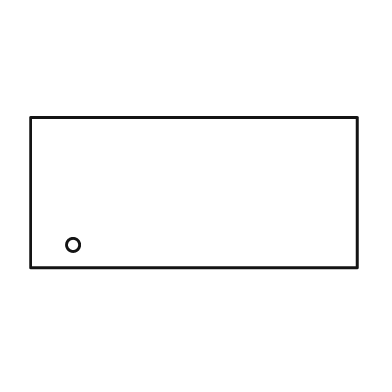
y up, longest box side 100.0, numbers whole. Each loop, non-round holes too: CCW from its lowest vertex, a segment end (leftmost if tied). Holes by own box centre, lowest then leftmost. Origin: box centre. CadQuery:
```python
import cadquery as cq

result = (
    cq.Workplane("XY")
    .moveTo(-50.0, -23.0)
    .lineTo(50.0, -23.0)
    .lineTo(50.0, 23.0)
    .lineTo(-50.0, 23.0)
    .close()
    .moveTo(-37.0, -16.0)
    .circle(2.0)
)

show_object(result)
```